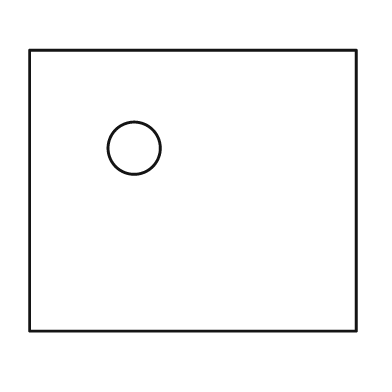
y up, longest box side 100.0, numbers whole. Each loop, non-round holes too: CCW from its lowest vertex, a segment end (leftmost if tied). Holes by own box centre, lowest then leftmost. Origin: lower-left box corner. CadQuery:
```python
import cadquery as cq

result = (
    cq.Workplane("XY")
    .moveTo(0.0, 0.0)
    .lineTo(100.0, 0.0)
    .lineTo(100.0, 86.0)
    .lineTo(0.0, 86.0)
    .close()
    .moveTo(32.0, 56.0)
    .circle(8.0)
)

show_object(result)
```